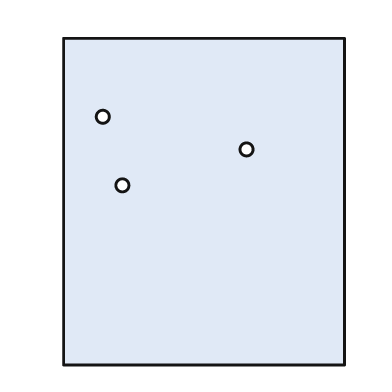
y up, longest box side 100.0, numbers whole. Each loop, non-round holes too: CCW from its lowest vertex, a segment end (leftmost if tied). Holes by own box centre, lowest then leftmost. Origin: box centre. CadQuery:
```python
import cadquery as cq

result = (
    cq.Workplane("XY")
    .moveTo(-43.0, -50.0)
    .lineTo(43.0, -50.0)
    .lineTo(43.0, 50.0)
    .lineTo(-43.0, 50.0)
    .close()
    .moveTo(-25.0, 5.0)
    .circle(2.0)
    .moveTo(13.0, 16.0)
    .circle(2.0)
    .moveTo(-31.0, 26.0)
    .circle(2.0)
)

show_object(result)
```